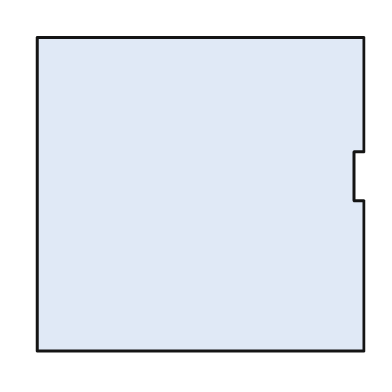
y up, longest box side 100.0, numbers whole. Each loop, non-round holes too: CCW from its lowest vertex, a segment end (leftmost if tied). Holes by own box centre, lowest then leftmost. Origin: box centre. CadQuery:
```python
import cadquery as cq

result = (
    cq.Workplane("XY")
    .moveTo(-50.0, -48.0)
    .lineTo(50.0, -48.0)
    .lineTo(50.0, -2.0)
    .lineTo(47.0, -2.0)
    .lineTo(47.0, 13.0)
    .lineTo(50.0, 13.0)
    .lineTo(50.0, 48.0)
    .lineTo(-50.0, 48.0)
    .close()
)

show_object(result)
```